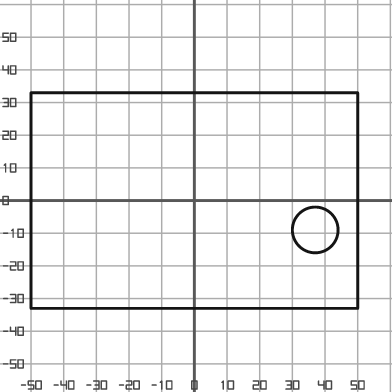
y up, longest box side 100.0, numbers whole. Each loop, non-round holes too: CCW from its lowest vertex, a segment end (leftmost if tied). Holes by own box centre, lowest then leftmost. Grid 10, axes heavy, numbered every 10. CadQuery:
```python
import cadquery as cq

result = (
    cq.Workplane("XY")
    .moveTo(-50.0, -33.0)
    .lineTo(50.0, -33.0)
    .lineTo(50.0, 33.0)
    .lineTo(-50.0, 33.0)
    .close()
    .moveTo(37.0, -9.0)
    .circle(7.0)
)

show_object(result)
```